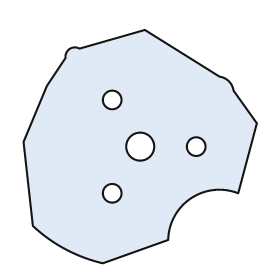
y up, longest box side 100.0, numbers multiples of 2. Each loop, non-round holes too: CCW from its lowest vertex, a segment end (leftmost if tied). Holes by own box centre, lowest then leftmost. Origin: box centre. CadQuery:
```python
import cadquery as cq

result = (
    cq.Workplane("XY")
    .moveTo(-16.0, -50.0)
    .lineTo(12.0, -40.0)
    .threePointArc((22.0, -22.0), (42.0, -20.0))
    .lineTo(50.0, 10.0)
    .lineTo(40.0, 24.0)
    .threePointArc((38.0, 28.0), (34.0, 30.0))
    .lineTo(2.0, 50.0)
    .lineTo(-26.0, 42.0)
    .threePointArc((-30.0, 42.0), (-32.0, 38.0))
    .lineTo(-40.0, 26.0)
    .lineTo(-50.0, 2.0)
    .lineTo(-46.0, -34.0)
    .threePointArc((-32.0, -44.0), (-16.0, -50.0))
    .close()
    .moveTo(-12.0, -20.0)
    .circle(4.0)
    .moveTo(0.0, 0.0)
    .circle(6.0)
    .moveTo(24.0, 0.0)
    .circle(4.0)
    .moveTo(-12.0, 20.0)
    .circle(4.0)
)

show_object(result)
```